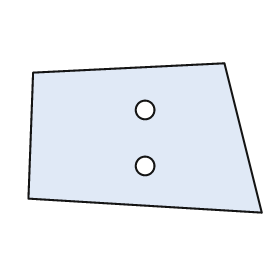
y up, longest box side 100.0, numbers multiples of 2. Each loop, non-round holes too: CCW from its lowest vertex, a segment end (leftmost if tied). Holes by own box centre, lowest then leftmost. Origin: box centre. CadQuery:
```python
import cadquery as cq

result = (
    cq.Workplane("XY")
    .moveTo(50.0, -32.0)
    .lineTo(34.0, 32.0)
    .lineTo(-48.0, 28.0)
    .lineTo(-50.0, -26.0)
    .close()
    .moveTo(0.0, -12.0)
    .circle(4.0)
    .moveTo(0.0, 12.0)
    .circle(4.0)
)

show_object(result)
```